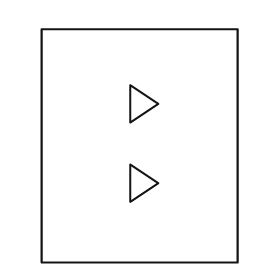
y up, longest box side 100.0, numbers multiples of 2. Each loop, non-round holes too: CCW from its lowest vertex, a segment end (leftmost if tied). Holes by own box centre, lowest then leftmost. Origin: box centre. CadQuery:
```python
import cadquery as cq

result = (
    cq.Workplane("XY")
    .moveTo(-42.0, -50.0)
    .lineTo(42.0, -50.0)
    .lineTo(42.0, 50.0)
    .lineTo(-42.0, 50.0)
    .close()
    .moveTo(-4.0, -24.0)
    .lineTo(8.0, -16.0)
    .lineTo(-4.0, -8.0)
    .close()
    .moveTo(-4.0, 10.0)
    .lineTo(8.0, 18.0)
    .lineTo(-4.0, 26.0)
    .close()
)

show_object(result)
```